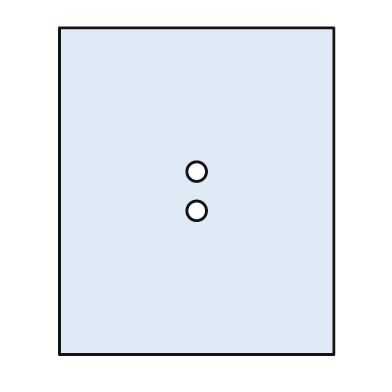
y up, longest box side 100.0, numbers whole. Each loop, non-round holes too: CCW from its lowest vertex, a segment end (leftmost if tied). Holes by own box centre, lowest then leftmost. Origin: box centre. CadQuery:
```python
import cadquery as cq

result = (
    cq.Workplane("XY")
    .moveTo(-42.0, -50.0)
    .lineTo(42.0, -50.0)
    .lineTo(42.0, 50.0)
    .lineTo(-42.0, 50.0)
    .close()
    .moveTo(0.0, -6.0)
    .circle(3.0)
    .moveTo(0.0, 6.0)
    .circle(3.0)
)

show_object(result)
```